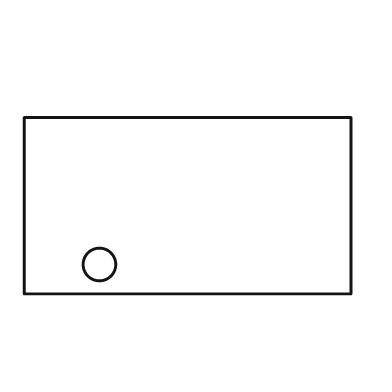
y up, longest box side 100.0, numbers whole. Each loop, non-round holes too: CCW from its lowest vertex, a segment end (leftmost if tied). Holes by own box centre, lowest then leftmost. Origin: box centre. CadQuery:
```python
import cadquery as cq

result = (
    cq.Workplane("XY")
    .moveTo(-50.0, -27.0)
    .lineTo(50.0, -27.0)
    .lineTo(50.0, 27.0)
    .lineTo(-50.0, 27.0)
    .close()
    .moveTo(-27.0, -18.0)
    .circle(5.0)
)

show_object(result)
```